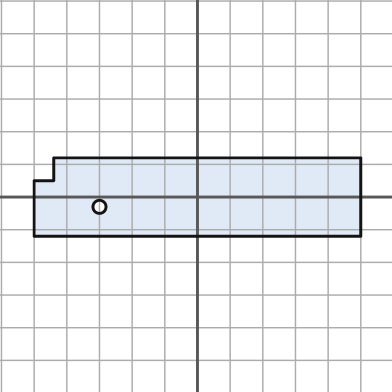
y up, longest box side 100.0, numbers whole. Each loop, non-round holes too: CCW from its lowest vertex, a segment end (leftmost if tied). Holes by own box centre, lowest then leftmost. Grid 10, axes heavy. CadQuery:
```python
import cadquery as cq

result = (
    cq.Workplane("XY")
    .moveTo(-50.0, -12.0)
    .lineTo(50.0, -12.0)
    .lineTo(50.0, 12.0)
    .lineTo(-44.0, 12.0)
    .lineTo(-44.0, 5.0)
    .lineTo(-50.0, 5.0)
    .close()
    .moveTo(-30.0, -3.0)
    .circle(2.0)
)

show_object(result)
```